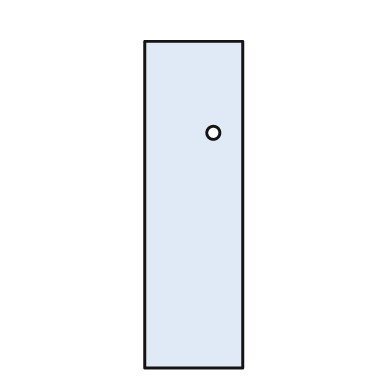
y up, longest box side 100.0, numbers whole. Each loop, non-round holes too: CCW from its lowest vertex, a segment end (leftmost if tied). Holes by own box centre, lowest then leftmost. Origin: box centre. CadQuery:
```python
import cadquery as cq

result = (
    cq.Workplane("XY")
    .moveTo(-15.0, -50.0)
    .lineTo(15.0, -50.0)
    .lineTo(15.0, 50.0)
    .lineTo(-15.0, 50.0)
    .close()
    .moveTo(6.0, 22.0)
    .circle(2.0)
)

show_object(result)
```